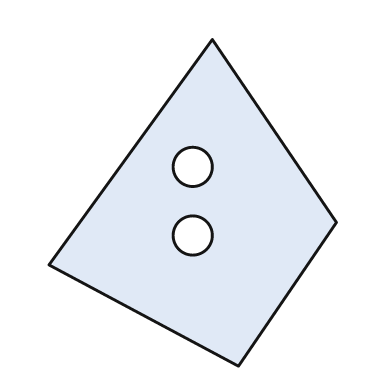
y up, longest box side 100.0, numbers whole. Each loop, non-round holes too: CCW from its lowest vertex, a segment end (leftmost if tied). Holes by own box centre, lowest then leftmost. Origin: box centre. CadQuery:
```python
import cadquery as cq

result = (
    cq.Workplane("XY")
    .moveTo(14.0, -50.0)
    .lineTo(44.0, -6.0)
    .lineTo(6.0, 50.0)
    .lineTo(-44.0, -19.0)
    .close()
    .moveTo(0.0, -10.0)
    .circle(6.0)
    .moveTo(0.0, 11.0)
    .circle(6.0)
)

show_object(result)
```